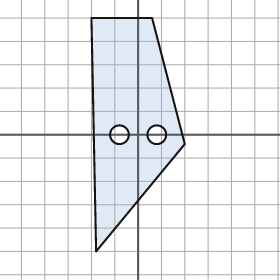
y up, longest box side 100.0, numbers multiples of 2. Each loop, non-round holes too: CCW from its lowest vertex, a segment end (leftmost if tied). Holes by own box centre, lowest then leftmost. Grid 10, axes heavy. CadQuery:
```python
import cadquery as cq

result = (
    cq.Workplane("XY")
    .moveTo(-18.0, -50.0)
    .lineTo(20.0, -4.0)
    .lineTo(6.0, 50.0)
    .lineTo(-20.0, 50.0)
    .close()
    .moveTo(-8.0, 0.0)
    .circle(4.0)
    .moveTo(8.0, 0.0)
    .circle(4.0)
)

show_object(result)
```